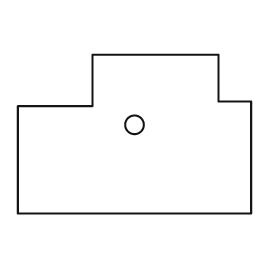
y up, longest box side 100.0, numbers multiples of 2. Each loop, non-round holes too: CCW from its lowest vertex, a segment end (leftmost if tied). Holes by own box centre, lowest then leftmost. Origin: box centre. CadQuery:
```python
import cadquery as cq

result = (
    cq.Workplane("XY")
    .moveTo(-50.0, -34.0)
    .lineTo(50.0, -34.0)
    .lineTo(50.0, 14.0)
    .lineTo(36.0, 14.0)
    .lineTo(36.0, 34.0)
    .lineTo(-18.0, 34.0)
    .lineTo(-18.0, 12.0)
    .lineTo(-50.0, 12.0)
    .close()
    .moveTo(0.0, 4.0)
    .circle(4.0)
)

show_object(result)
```